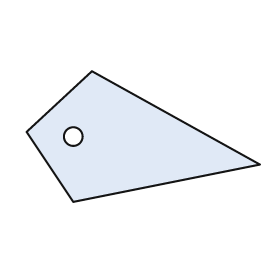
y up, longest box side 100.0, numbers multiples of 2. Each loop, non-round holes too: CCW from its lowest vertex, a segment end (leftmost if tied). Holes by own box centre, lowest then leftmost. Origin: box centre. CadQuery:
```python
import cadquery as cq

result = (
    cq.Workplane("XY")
    .moveTo(-30.0, -28.0)
    .lineTo(50.0, -12.0)
    .lineTo(-22.0, 28.0)
    .lineTo(-50.0, 2.0)
    .close()
    .moveTo(-30.0, 0.0)
    .circle(4.0)
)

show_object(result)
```